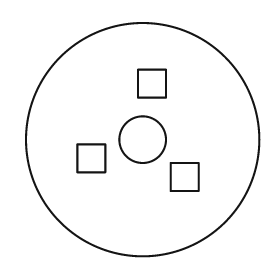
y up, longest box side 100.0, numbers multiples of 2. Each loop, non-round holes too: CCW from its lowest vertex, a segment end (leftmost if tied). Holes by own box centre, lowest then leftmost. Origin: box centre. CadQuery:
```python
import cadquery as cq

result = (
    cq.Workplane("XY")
    .moveTo(0.0, 0.0)
    .circle(50.0)
    .moveTo(12.0, -22.0)
    .lineTo(24.0, -22.0)
    .lineTo(24.0, -10.0)
    .lineTo(12.0, -10.0)
    .close()
    .moveTo(-28.0, -14.0)
    .lineTo(-16.0, -14.0)
    .lineTo(-16.0, -2.0)
    .lineTo(-28.0, -2.0)
    .close()
    .moveTo(0.0, 0.0)
    .circle(10.0)
    .moveTo(-2.0, 18.0)
    .lineTo(10.0, 18.0)
    .lineTo(10.0, 30.0)
    .lineTo(-2.0, 30.0)
    .close()
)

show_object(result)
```